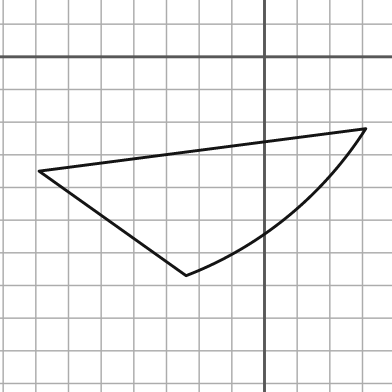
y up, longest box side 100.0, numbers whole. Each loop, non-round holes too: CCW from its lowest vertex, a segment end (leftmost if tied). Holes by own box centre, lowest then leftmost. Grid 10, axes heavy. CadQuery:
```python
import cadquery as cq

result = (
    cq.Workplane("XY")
    .moveTo(-24.0, -67.0)
    .threePointArc((7.0, -49.0), (31.0, -22.0))
    .lineTo(-69.0, -35.0)
    .close()
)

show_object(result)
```